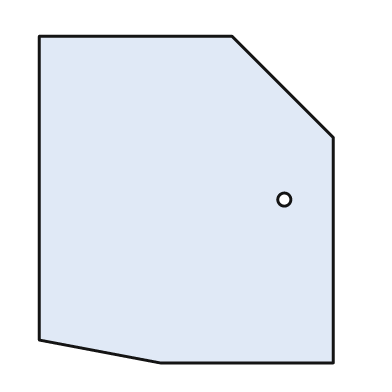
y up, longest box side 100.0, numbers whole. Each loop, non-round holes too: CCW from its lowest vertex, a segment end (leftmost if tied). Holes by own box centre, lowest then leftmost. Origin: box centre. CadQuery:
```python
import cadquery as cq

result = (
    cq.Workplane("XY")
    .moveTo(-8.0, -50.0)
    .lineTo(45.0, -50.0)
    .lineTo(45.0, 19.0)
    .lineTo(14.0, 50.0)
    .lineTo(-45.0, 50.0)
    .lineTo(-45.0, -43.0)
    .close()
    .moveTo(30.0, 0.0)
    .circle(2.0)
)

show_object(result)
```